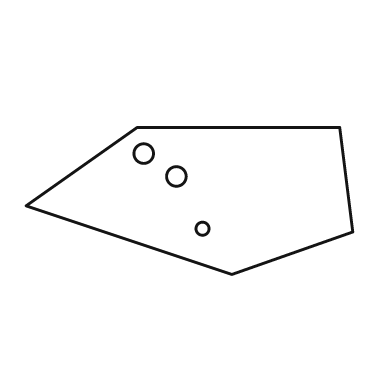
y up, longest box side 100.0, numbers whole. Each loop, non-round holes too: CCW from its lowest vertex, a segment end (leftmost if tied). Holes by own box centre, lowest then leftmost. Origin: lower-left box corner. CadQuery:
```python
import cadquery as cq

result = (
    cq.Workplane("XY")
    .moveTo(63.0, 0.0)
    .lineTo(100.0, 13.0)
    .lineTo(96.0, 45.0)
    .lineTo(34.0, 45.0)
    .lineTo(0.0, 21.0)
    .close()
    .moveTo(54.0, 14.0)
    .circle(2.0)
    .moveTo(46.0, 30.0)
    .circle(3.0)
    .moveTo(36.0, 37.0)
    .circle(3.0)
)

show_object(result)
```